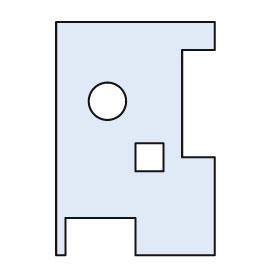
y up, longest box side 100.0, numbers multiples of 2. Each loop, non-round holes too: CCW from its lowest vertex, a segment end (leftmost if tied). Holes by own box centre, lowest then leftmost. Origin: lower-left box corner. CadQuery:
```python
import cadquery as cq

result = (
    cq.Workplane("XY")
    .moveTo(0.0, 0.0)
    .lineTo(4.0, 0.0)
    .lineTo(4.0, 16.0)
    .lineTo(34.0, 16.0)
    .lineTo(34.0, 0.0)
    .lineTo(68.0, 0.0)
    .lineTo(68.0, 42.0)
    .lineTo(54.0, 42.0)
    .lineTo(54.0, 88.0)
    .lineTo(68.0, 88.0)
    .lineTo(68.0, 100.0)
    .lineTo(0.0, 100.0)
    .close()
    .moveTo(34.0, 36.0)
    .lineTo(46.0, 36.0)
    .lineTo(46.0, 48.0)
    .lineTo(34.0, 48.0)
    .close()
    .moveTo(22.0, 66.0)
    .circle(8.0)
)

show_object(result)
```